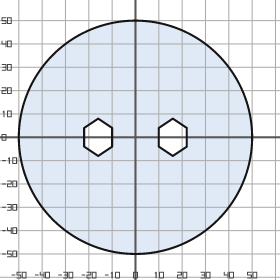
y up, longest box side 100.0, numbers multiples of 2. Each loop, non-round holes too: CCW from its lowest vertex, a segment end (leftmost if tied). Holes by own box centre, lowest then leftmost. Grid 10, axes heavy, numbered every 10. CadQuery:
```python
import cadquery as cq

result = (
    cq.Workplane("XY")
    .moveTo(0.0, 0.0)
    .circle(50.0)
    .moveTo(-16.0, -8.0)
    .lineTo(-10.0, -4.0)
    .lineTo(-10.0, 4.0)
    .lineTo(-16.0, 8.0)
    .lineTo(-22.0, 4.0)
    .lineTo(-22.0, -4.0)
    .close()
    .moveTo(16.0, -8.0)
    .lineTo(22.0, -4.0)
    .lineTo(22.0, 4.0)
    .lineTo(16.0, 8.0)
    .lineTo(10.0, 4.0)
    .lineTo(10.0, -4.0)
    .close()
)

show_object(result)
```